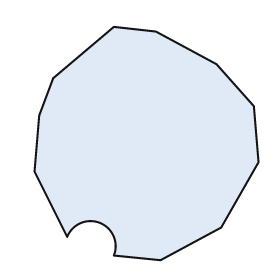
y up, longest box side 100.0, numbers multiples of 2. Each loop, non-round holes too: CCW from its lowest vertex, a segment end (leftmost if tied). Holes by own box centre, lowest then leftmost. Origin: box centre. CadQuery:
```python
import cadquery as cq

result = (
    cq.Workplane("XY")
    .moveTo(6.0, -50.0)
    .lineTo(32.0, -36.0)
    .lineTo(48.0, -8.0)
    .lineTo(46.0, 16.0)
    .lineTo(30.0, 34.0)
    .lineTo(4.0, 48.0)
    .lineTo(-14.0, 50.0)
    .lineTo(-40.0, 28.0)
    .lineTo(-46.0, 12.0)
    .lineTo(-48.0, -12.0)
    .lineTo(-34.0, -40.0)
    .threePointArc((-20.0, -34.0), (-14.0, -48.0))
    .close()
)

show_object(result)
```